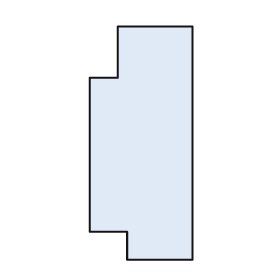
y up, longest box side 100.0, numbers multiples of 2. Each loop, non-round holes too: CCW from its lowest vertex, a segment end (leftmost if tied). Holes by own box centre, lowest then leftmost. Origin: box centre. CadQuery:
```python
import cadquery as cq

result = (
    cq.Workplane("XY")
    .moveTo(-6.0, -50.0)
    .lineTo(22.0, -50.0)
    .lineTo(22.0, 50.0)
    .lineTo(-10.0, 50.0)
    .lineTo(-10.0, 28.0)
    .lineTo(-22.0, 28.0)
    .lineTo(-22.0, -38.0)
    .lineTo(-6.0, -38.0)
    .close()
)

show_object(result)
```